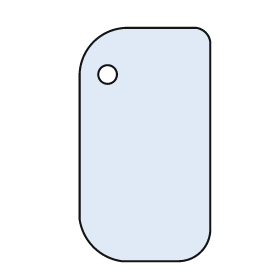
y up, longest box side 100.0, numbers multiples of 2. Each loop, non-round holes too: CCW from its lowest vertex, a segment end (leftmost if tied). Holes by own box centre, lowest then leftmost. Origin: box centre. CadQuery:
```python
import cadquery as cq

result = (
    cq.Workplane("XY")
    .moveTo(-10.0, -50.0)
    .lineTo(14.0, -50.0)
    .threePointArc((24.0, -46.0), (28.0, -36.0))
    .lineTo(28.0, 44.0)
    .threePointArc((26.0, 48.0), (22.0, 50.0))
    .lineTo(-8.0, 50.0)
    .threePointArc((-22.0, 44.0), (-28.0, 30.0))
    .lineTo(-28.0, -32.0)
    .threePointArc((-22.0, -44.0), (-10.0, -50.0))
    .close()
    .moveTo(-16.0, 30.0)
    .circle(4.0)
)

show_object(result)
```